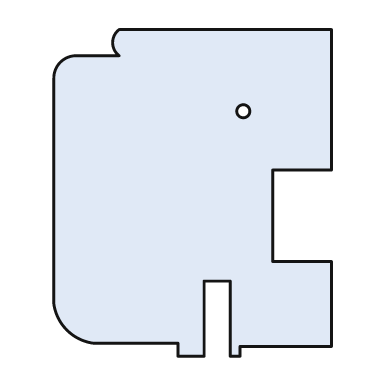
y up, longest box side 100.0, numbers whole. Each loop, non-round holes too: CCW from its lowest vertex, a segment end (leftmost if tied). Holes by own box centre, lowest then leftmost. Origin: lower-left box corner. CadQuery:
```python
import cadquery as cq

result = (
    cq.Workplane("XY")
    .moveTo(38.0, 0.0)
    .lineTo(46.0, 0.0)
    .lineTo(46.0, 23.0)
    .lineTo(54.0, 23.0)
    .lineTo(54.0, 0.0)
    .lineTo(57.0, 0.0)
    .lineTo(57.0, 3.0)
    .lineTo(85.0, 3.0)
    .lineTo(85.0, 29.0)
    .lineTo(67.0, 29.0)
    .lineTo(67.0, 57.0)
    .lineTo(85.0, 57.0)
    .lineTo(85.0, 100.0)
    .lineTo(20.0, 100.0)
    .threePointArc((18.0, 96.0), (20.0, 92.0))
    .lineTo(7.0, 92.0)
    .threePointArc((2.0, 90.0), (0.0, 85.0))
    .lineTo(0.0, 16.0)
    .threePointArc((4.0, 8.0), (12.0, 4.0))
    .lineTo(38.0, 4.0)
    .close()
    .moveTo(58.0, 75.0)
    .circle(2.0)
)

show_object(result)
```